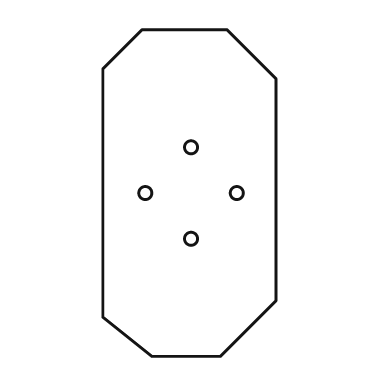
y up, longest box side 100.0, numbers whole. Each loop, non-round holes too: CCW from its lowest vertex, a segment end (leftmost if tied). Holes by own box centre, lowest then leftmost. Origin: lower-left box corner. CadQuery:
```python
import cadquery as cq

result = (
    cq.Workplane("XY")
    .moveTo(15.0, 0.0)
    .lineTo(36.0, 0.0)
    .lineTo(53.0, 17.0)
    .lineTo(53.0, 85.0)
    .lineTo(38.0, 100.0)
    .lineTo(12.0, 100.0)
    .lineTo(0.0, 88.0)
    .lineTo(0.0, 12.0)
    .close()
    .moveTo(27.0, 36.0)
    .circle(2.0)
    .moveTo(13.0, 50.0)
    .circle(2.0)
    .moveTo(41.0, 50.0)
    .circle(2.0)
    .moveTo(27.0, 64.0)
    .circle(2.0)
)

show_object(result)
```